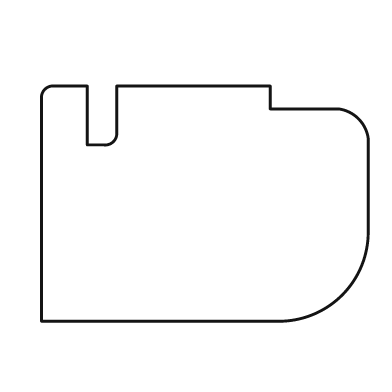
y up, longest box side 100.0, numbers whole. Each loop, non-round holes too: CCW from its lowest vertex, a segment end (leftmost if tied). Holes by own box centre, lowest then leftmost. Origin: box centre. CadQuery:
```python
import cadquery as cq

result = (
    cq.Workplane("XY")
    .moveTo(-50.0, -36.0)
    .lineTo(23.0, -36.0)
    .threePointArc((42.0, -28.0), (50.0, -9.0))
    .lineTo(50.0, 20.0)
    .threePointArc((47.0, 26.0), (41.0, 29.0))
    .lineTo(20.0, 29.0)
    .lineTo(20.0, 36.0)
    .lineTo(-27.0, 36.0)
    .lineTo(-27.0, 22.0)
    .threePointArc((-28.0, 19.0), (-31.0, 18.0))
    .lineTo(-36.0, 18.0)
    .lineTo(-36.0, 36.0)
    .lineTo(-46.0, 36.0)
    .threePointArc((-49.0, 35.0), (-50.0, 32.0))
    .close()
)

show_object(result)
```